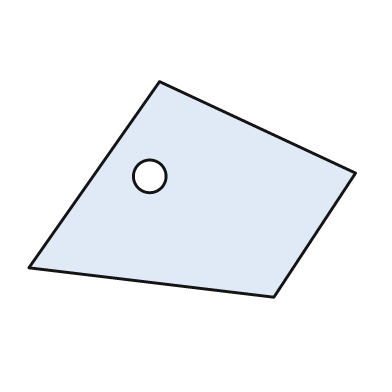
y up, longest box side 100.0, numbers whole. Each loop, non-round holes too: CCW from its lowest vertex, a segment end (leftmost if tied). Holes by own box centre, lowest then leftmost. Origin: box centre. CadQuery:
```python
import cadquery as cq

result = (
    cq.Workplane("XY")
    .moveTo(25.0, -33.0)
    .lineTo(50.0, 5.0)
    .lineTo(-10.0, 33.0)
    .lineTo(-50.0, -24.0)
    .close()
    .moveTo(-13.0, 4.0)
    .circle(5.0)
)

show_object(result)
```